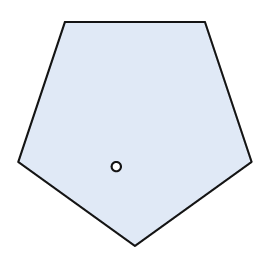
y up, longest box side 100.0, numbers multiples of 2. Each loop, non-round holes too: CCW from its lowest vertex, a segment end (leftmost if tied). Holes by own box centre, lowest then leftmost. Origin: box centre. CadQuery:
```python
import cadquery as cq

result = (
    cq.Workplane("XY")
    .moveTo(0.0, -48.0)
    .lineTo(50.0, -12.0)
    .lineTo(30.0, 48.0)
    .lineTo(-30.0, 48.0)
    .lineTo(-50.0, -12.0)
    .close()
    .moveTo(-8.0, -14.0)
    .circle(2.0)
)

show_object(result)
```